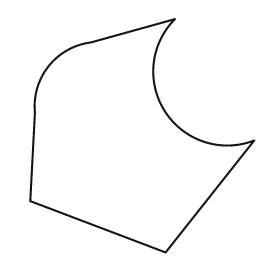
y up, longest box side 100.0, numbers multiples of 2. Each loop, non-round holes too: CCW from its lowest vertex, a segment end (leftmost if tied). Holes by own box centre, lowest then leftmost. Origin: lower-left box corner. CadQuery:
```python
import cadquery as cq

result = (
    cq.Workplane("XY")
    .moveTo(58.0, 0.0)
    .lineTo(96.0, 48.0)
    .threePointArc((58.0, 60.0), (62.0, 100.0))
    .lineTo(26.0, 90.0)
    .threePointArc((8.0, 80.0), (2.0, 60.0))
    .lineTo(0.0, 22.0)
    .close()
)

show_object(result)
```